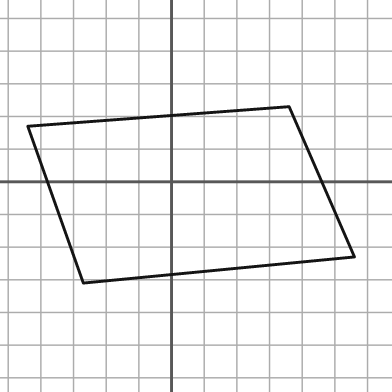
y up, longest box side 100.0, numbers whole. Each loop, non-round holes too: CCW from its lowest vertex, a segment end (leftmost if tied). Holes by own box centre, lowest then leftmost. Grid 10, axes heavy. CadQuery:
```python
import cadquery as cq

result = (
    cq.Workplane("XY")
    .moveTo(-27.0, -31.0)
    .lineTo(56.0, -23.0)
    .lineTo(36.0, 23.0)
    .lineTo(-44.0, 17.0)
    .close()
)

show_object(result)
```